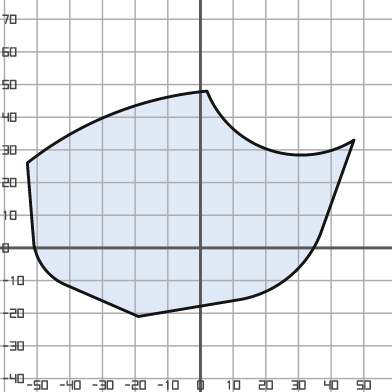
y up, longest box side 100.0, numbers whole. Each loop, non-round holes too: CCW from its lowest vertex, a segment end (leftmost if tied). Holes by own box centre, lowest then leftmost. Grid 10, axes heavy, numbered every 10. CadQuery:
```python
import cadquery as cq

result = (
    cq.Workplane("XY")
    .moveTo(-19.0, -21.0)
    .lineTo(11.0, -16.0)
    .threePointArc((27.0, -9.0), (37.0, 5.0))
    .lineTo(47.0, 33.0)
    .threePointArc((21.0, 30.0), (2.0, 48.0))
    .threePointArc((-27.0, 41.0), (-53.0, 26.0))
    .lineTo(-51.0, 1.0)
    .threePointArc((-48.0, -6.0), (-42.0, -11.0))
    .close()
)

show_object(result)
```